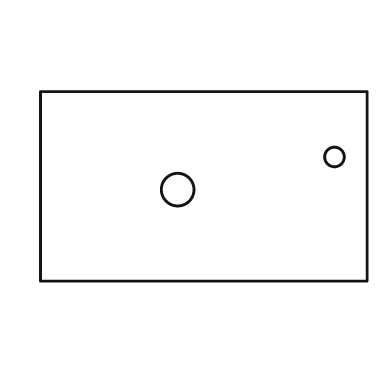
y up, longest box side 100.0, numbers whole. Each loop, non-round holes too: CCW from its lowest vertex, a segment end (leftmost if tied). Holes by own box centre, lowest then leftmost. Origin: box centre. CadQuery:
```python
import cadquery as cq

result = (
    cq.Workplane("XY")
    .moveTo(-50.0, -29.0)
    .lineTo(50.0, -29.0)
    .lineTo(50.0, 29.0)
    .lineTo(-50.0, 29.0)
    .close()
    .moveTo(-8.0, -1.0)
    .circle(5.0)
    .moveTo(40.0, 9.0)
    .circle(3.0)
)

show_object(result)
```